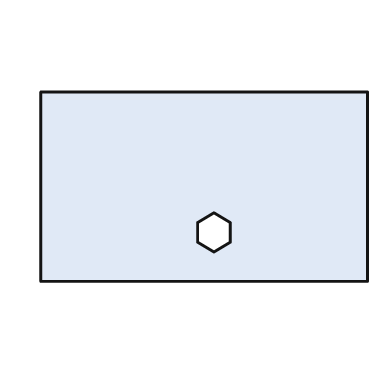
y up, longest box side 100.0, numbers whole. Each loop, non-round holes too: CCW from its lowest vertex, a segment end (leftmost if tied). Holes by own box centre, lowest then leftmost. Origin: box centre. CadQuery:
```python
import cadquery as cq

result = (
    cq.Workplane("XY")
    .moveTo(-50.0, -29.0)
    .lineTo(50.0, -29.0)
    .lineTo(50.0, 29.0)
    .lineTo(-50.0, 29.0)
    .close()
    .moveTo(3.0, -20.0)
    .lineTo(8.0, -17.0)
    .lineTo(8.0, -11.0)
    .lineTo(3.0, -8.0)
    .lineTo(-2.0, -11.0)
    .lineTo(-2.0, -17.0)
    .close()
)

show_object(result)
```